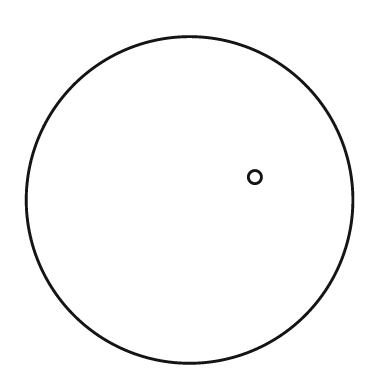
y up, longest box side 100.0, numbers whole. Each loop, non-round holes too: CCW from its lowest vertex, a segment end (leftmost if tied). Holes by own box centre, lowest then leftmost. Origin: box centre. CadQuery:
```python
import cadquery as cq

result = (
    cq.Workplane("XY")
    .moveTo(0.0, 0.0)
    .circle(50.0)
    .moveTo(20.0, 7.0)
    .circle(2.0)
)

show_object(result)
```